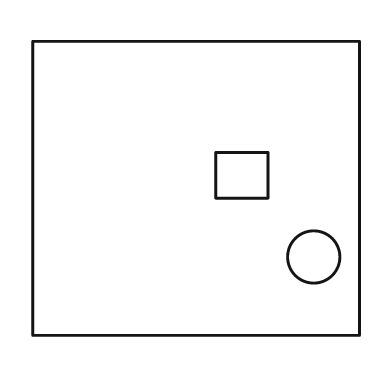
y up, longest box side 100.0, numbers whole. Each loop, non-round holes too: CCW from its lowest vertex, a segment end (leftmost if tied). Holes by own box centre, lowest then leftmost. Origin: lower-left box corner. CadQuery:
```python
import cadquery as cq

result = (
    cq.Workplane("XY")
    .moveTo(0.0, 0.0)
    .lineTo(100.0, 0.0)
    .lineTo(100.0, 90.0)
    .lineTo(0.0, 90.0)
    .close()
    .moveTo(86.0, 24.0)
    .circle(8.0)
    .moveTo(56.0, 42.0)
    .lineTo(72.0, 42.0)
    .lineTo(72.0, 56.0)
    .lineTo(56.0, 56.0)
    .close()
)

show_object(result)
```